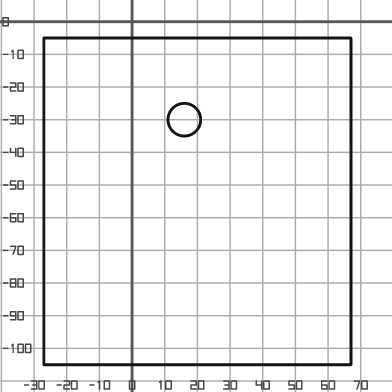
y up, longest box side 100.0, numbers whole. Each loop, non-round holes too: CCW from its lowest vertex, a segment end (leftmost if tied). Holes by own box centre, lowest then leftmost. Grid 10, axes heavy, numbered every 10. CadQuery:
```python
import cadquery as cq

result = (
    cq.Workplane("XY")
    .moveTo(-27.0, -105.0)
    .lineTo(67.0, -105.0)
    .lineTo(67.0, -5.0)
    .lineTo(-27.0, -5.0)
    .close()
    .moveTo(16.0, -30.0)
    .circle(5.0)
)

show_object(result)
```